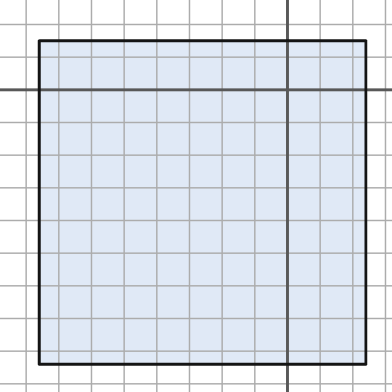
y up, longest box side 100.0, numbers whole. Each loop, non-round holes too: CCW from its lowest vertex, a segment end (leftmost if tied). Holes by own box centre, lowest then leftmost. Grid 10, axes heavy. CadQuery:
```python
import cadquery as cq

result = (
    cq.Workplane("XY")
    .moveTo(-76.0, -84.0)
    .lineTo(24.0, -84.0)
    .lineTo(24.0, 15.0)
    .lineTo(-76.0, 15.0)
    .close()
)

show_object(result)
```